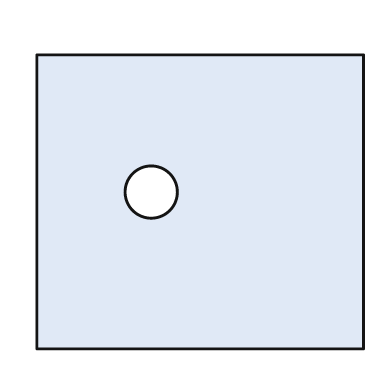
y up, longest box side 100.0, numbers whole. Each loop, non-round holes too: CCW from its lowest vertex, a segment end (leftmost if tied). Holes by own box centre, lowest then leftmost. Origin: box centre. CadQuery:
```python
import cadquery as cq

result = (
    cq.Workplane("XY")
    .moveTo(-50.0, -45.0)
    .lineTo(50.0, -45.0)
    .lineTo(50.0, 45.0)
    .lineTo(-50.0, 45.0)
    .close()
    .moveTo(-15.0, 3.0)
    .circle(8.0)
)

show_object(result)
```